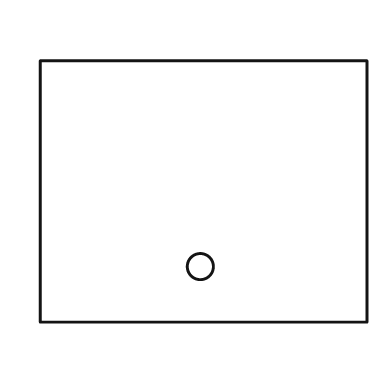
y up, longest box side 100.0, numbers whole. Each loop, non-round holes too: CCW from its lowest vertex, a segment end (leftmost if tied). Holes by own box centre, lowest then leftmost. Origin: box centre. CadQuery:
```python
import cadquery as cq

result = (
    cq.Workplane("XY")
    .moveTo(-50.0, -40.0)
    .lineTo(50.0, -40.0)
    .lineTo(50.0, 40.0)
    .lineTo(-50.0, 40.0)
    .close()
    .moveTo(-1.0, -23.0)
    .circle(4.0)
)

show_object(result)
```